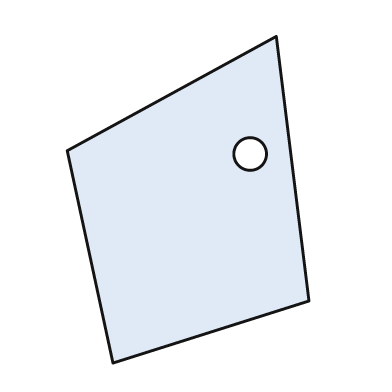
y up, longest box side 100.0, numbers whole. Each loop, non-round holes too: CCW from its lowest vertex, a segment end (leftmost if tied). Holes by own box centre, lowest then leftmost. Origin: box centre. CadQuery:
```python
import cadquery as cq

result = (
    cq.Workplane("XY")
    .moveTo(-23.0, -50.0)
    .lineTo(37.0, -31.0)
    .lineTo(27.0, 50.0)
    .lineTo(-37.0, 15.0)
    .close()
    .moveTo(19.0, 14.0)
    .circle(5.0)
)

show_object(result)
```